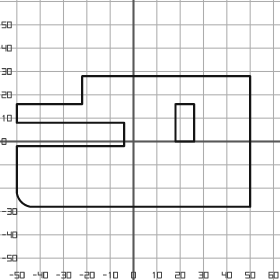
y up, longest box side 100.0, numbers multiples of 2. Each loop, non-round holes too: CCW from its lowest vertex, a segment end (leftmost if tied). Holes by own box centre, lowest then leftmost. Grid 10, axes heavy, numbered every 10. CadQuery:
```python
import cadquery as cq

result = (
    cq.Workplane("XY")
    .moveTo(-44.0, -28.0)
    .lineTo(50.0, -28.0)
    .lineTo(50.0, 28.0)
    .lineTo(-22.0, 28.0)
    .lineTo(-22.0, 16.0)
    .lineTo(-50.0, 16.0)
    .lineTo(-50.0, 8.0)
    .lineTo(-4.0, 8.0)
    .lineTo(-4.0, -2.0)
    .lineTo(-50.0, -2.0)
    .lineTo(-50.0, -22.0)
    .threePointArc((-48.0, -26.0), (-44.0, -28.0))
    .close()
    .moveTo(18.0, 0.0)
    .lineTo(26.0, 0.0)
    .lineTo(26.0, 16.0)
    .lineTo(18.0, 16.0)
    .close()
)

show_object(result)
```